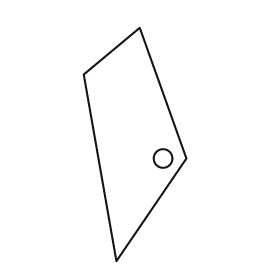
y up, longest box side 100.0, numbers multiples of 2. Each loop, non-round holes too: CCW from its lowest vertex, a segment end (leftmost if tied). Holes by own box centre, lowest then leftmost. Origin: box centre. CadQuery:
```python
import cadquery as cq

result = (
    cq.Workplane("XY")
    .moveTo(-8.0, -50.0)
    .lineTo(22.0, -6.0)
    .lineTo(2.0, 50.0)
    .lineTo(-22.0, 30.0)
    .close()
    .moveTo(12.0, -6.0)
    .circle(4.0)
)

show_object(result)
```